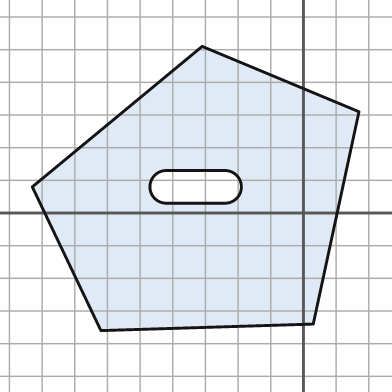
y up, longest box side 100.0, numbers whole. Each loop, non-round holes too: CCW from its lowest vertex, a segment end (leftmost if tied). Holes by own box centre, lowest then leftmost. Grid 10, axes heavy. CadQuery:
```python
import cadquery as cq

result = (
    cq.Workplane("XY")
    .moveTo(-62.0, -36.0)
    .lineTo(3.0, -34.0)
    .lineTo(17.0, 31.0)
    .lineTo(-31.0, 51.0)
    .lineTo(-83.0, 8.0)
    .close()
    .moveTo(-42.0, 3.0)
    .lineTo(-24.0, 3.0)
    .threePointArc((-19.0, 8.0), (-24.0, 13.0))
    .lineTo(-42.0, 13.0)
    .threePointArc((-47.0, 8.0), (-42.0, 3.0))
    .close()
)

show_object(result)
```